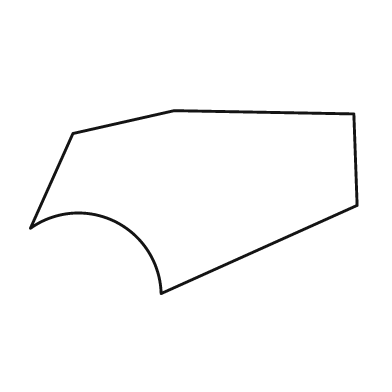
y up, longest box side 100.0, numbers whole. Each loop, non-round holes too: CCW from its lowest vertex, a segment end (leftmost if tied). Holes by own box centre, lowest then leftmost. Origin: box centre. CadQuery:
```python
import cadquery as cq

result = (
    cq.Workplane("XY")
    .moveTo(-10.0, -28.0)
    .lineTo(50.0, -1.0)
    .lineTo(49.0, 27.0)
    .lineTo(-6.0, 28.0)
    .lineTo(-37.0, 21.0)
    .lineTo(-50.0, -8.0)
    .threePointArc((-24.0, -6.0), (-10.0, -28.0))
    .close()
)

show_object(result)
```